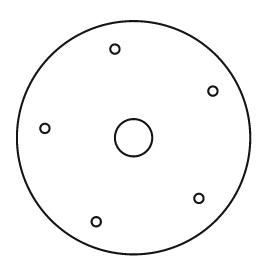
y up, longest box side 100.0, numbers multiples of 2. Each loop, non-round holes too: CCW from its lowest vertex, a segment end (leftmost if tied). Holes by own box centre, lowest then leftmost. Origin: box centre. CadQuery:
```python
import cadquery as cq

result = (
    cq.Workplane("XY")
    .moveTo(0.0, 0.0)
    .circle(50.0)
    .moveTo(-16.0, -36.0)
    .circle(2.0)
    .moveTo(28.0, -26.0)
    .circle(2.0)
    .moveTo(0.0, 0.0)
    .circle(8.0)
    .moveTo(-38.0, 4.0)
    .circle(2.0)
    .moveTo(34.0, 20.0)
    .circle(2.0)
    .moveTo(-8.0, 38.0)
    .circle(2.0)
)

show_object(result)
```